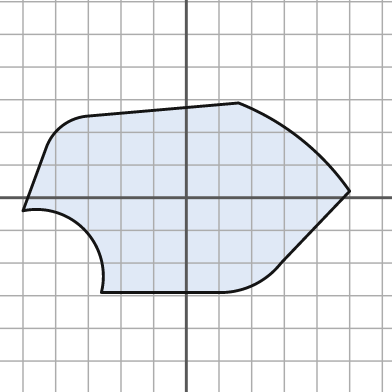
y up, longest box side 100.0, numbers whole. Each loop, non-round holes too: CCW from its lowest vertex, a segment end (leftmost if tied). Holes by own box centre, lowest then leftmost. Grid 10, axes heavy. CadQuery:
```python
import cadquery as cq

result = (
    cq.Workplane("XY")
    .moveTo(-26.0, -29.0)
    .lineTo(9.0, -29.0)
    .threePointArc((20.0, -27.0), (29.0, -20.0))
    .lineTo(50.0, 2.0)
    .threePointArc((35.0, 18.0), (16.0, 29.0))
    .lineTo(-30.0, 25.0)
    .threePointArc((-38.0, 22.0), (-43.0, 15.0))
    .lineTo(-50.0, -4.0)
    .threePointArc((-31.0, -10.0), (-26.0, -29.0))
    .close()
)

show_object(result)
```